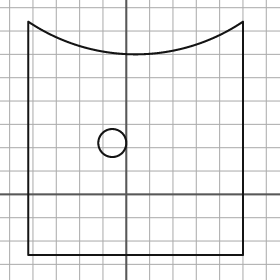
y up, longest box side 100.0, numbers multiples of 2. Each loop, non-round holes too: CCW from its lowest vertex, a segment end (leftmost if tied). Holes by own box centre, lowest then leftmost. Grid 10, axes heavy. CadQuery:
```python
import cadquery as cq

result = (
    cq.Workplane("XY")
    .moveTo(-42.0, -26.0)
    .lineTo(50.0, -26.0)
    .lineTo(50.0, 74.0)
    .threePointArc((4.0, 60.0), (-42.0, 74.0))
    .close()
    .moveTo(-6.0, 22.0)
    .circle(6.0)
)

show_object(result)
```